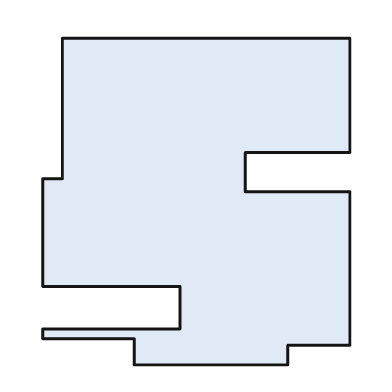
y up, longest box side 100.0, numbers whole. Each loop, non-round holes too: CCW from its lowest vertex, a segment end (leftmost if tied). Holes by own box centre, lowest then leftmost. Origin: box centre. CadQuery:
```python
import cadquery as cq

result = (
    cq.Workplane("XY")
    .moveTo(-19.0, -50.0)
    .lineTo(28.0, -50.0)
    .lineTo(28.0, -44.0)
    .lineTo(47.0, -44.0)
    .lineTo(47.0, 3.0)
    .lineTo(15.0, 3.0)
    .lineTo(15.0, 15.0)
    .lineTo(47.0, 15.0)
    .lineTo(47.0, 50.0)
    .lineTo(-41.0, 50.0)
    .lineTo(-41.0, 7.0)
    .lineTo(-47.0, 7.0)
    .lineTo(-47.0, -26.0)
    .lineTo(-5.0, -26.0)
    .lineTo(-5.0, -39.0)
    .lineTo(-47.0, -39.0)
    .lineTo(-47.0, -42.0)
    .lineTo(-19.0, -42.0)
    .close()
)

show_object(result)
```